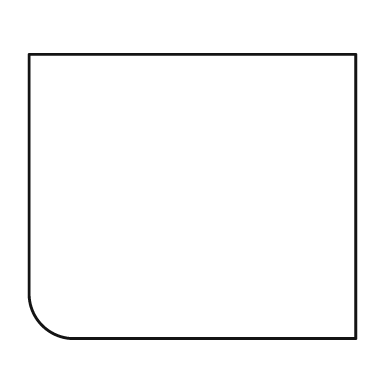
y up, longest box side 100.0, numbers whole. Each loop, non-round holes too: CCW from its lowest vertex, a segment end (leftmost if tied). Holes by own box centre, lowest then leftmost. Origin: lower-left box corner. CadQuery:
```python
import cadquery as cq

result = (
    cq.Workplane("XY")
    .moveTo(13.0, 0.0)
    .lineTo(100.0, 0.0)
    .lineTo(100.0, 87.0)
    .lineTo(0.0, 87.0)
    .lineTo(0.0, 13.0)
    .threePointArc((4.0, 4.0), (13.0, 0.0))
    .close()
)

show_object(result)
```